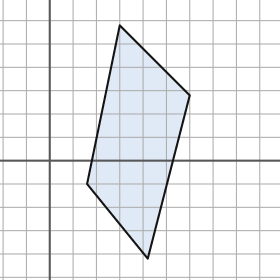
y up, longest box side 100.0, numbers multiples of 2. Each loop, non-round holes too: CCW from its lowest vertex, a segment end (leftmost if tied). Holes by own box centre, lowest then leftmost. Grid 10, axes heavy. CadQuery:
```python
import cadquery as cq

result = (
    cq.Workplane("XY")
    .moveTo(42.0, -42.0)
    .lineTo(60.0, 28.0)
    .lineTo(30.0, 58.0)
    .lineTo(16.0, -10.0)
    .close()
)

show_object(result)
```